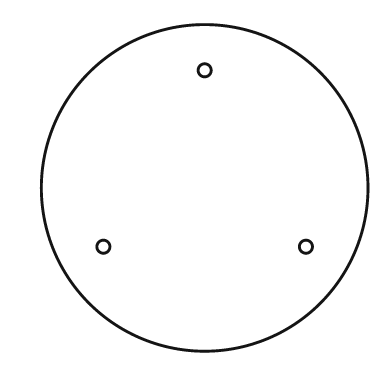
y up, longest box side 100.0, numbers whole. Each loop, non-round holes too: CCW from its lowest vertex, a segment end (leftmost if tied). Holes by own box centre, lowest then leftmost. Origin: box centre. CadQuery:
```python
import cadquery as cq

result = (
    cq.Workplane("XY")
    .moveTo(0.0, 0.0)
    .circle(50.0)
    .moveTo(-31.0, -18.0)
    .circle(2.0)
    .moveTo(31.0, -18.0)
    .circle(2.0)
    .moveTo(0.0, 36.0)
    .circle(2.0)
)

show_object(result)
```